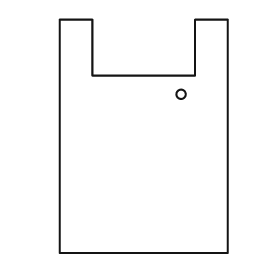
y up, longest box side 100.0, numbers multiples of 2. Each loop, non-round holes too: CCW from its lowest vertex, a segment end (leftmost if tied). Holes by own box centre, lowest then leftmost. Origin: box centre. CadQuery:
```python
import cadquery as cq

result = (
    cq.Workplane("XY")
    .moveTo(-36.0, -50.0)
    .lineTo(36.0, -50.0)
    .lineTo(36.0, 50.0)
    .lineTo(22.0, 50.0)
    .lineTo(22.0, 26.0)
    .lineTo(-22.0, 26.0)
    .lineTo(-22.0, 50.0)
    .lineTo(-36.0, 50.0)
    .close()
    .moveTo(16.0, 18.0)
    .circle(2.0)
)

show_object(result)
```